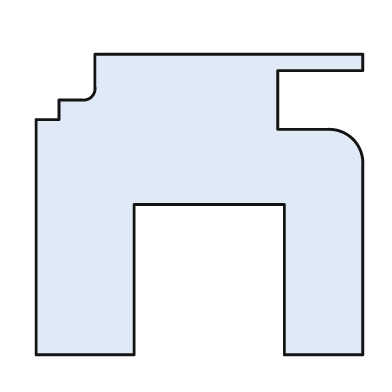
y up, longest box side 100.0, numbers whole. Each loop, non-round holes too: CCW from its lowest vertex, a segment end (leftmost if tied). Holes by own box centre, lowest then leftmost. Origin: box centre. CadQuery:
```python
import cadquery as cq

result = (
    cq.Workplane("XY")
    .moveTo(-50.0, -46.0)
    .lineTo(-20.0, -46.0)
    .lineTo(-20.0, 0.0)
    .lineTo(26.0, 0.0)
    .lineTo(26.0, -46.0)
    .lineTo(50.0, -46.0)
    .lineTo(50.0, 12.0)
    .threePointArc((47.0, 20.0), (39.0, 23.0))
    .lineTo(24.0, 23.0)
    .lineTo(24.0, 41.0)
    .lineTo(50.0, 41.0)
    .lineTo(50.0, 46.0)
    .lineTo(-32.0, 46.0)
    .lineTo(-32.0, 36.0)
    .threePointArc((-33.0, 33.0), (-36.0, 32.0))
    .lineTo(-43.0, 32.0)
    .lineTo(-43.0, 26.0)
    .lineTo(-50.0, 26.0)
    .close()
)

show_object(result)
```